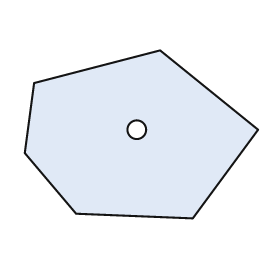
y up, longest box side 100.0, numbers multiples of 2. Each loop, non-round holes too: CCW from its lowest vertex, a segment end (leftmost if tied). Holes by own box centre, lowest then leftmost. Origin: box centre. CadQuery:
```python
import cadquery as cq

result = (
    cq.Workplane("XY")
    .moveTo(22.0, -36.0)
    .lineTo(50.0, 2.0)
    .lineTo(8.0, 36.0)
    .lineTo(-46.0, 22.0)
    .lineTo(-50.0, -8.0)
    .lineTo(-28.0, -34.0)
    .close()
    .moveTo(-2.0, 2.0)
    .circle(4.0)
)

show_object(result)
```